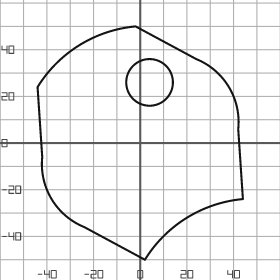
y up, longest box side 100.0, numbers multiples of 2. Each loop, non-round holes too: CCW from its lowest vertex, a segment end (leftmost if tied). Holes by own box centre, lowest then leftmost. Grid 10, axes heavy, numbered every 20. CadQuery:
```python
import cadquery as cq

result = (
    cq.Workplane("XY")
    .moveTo(2.0, -50.0)
    .threePointArc((20.0, -32.0), (44.0, -24.0))
    .lineTo(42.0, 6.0)
    .threePointArc((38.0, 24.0), (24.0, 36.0))
    .lineTo(-2.0, 50.0)
    .threePointArc((-26.0, 42.0), (-44.0, 24.0))
    .lineTo(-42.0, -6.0)
    .threePointArc((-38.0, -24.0), (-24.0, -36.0))
    .close()
    .moveTo(4.0, 26.0)
    .circle(10.0)
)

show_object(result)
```